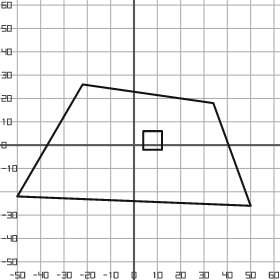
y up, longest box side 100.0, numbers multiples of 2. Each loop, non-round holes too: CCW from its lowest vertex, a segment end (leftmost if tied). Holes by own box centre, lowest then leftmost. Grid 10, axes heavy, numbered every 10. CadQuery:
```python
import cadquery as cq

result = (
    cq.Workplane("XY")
    .moveTo(50.0, -26.0)
    .lineTo(34.0, 18.0)
    .lineTo(-22.0, 26.0)
    .lineTo(-50.0, -22.0)
    .close()
    .moveTo(4.0, -2.0)
    .lineTo(12.0, -2.0)
    .lineTo(12.0, 6.0)
    .lineTo(4.0, 6.0)
    .close()
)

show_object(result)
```